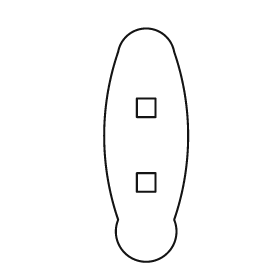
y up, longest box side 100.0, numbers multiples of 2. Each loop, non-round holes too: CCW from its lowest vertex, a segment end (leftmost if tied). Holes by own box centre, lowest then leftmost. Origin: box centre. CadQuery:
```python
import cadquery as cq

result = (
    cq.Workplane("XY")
    .moveTo(-12.0, -32.0)
    .threePointArc((0.0, -50.0), (12.0, -32.0))
    .threePointArc((18.0, 4.0), (12.0, 40.0))
    .threePointArc((0.0, 50.0), (-12.0, 40.0))
    .threePointArc((-18.0, 4.0), (-12.0, -32.0))
    .close()
    .moveTo(-4.0, -20.0)
    .lineTo(4.0, -20.0)
    .lineTo(4.0, -12.0)
    .lineTo(-4.0, -12.0)
    .close()
    .moveTo(-4.0, 12.0)
    .lineTo(4.0, 12.0)
    .lineTo(4.0, 20.0)
    .lineTo(-4.0, 20.0)
    .close()
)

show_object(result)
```